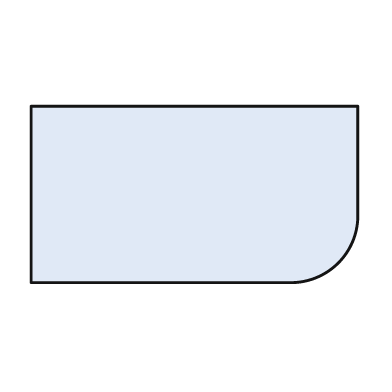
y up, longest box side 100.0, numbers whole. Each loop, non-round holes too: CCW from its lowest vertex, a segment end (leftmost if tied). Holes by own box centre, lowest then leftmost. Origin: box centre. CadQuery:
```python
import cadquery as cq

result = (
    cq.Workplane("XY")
    .moveTo(-50.0, -27.0)
    .lineTo(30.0, -27.0)
    .threePointArc((44.0, -21.0), (50.0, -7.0))
    .lineTo(50.0, 27.0)
    .lineTo(-50.0, 27.0)
    .close()
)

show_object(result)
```